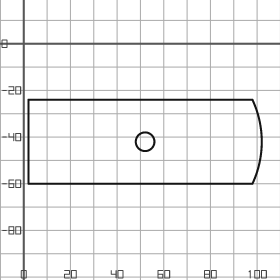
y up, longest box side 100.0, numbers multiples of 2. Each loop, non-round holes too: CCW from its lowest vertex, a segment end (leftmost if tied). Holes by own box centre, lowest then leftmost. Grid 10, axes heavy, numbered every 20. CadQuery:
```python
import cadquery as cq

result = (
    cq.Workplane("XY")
    .moveTo(2.0, -60.0)
    .lineTo(98.0, -60.0)
    .threePointArc((102.0, -42.0), (98.0, -24.0))
    .lineTo(2.0, -24.0)
    .close()
    .moveTo(52.0, -42.0)
    .circle(4.0)
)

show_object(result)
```